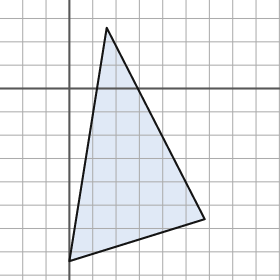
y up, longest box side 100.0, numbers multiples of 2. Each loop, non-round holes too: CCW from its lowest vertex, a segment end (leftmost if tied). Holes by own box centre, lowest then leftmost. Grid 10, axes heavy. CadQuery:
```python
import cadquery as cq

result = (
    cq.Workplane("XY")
    .moveTo(0.0, -74.0)
    .lineTo(58.0, -56.0)
    .lineTo(16.0, 26.0)
    .close()
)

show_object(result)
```